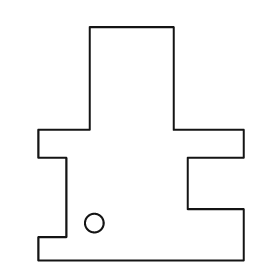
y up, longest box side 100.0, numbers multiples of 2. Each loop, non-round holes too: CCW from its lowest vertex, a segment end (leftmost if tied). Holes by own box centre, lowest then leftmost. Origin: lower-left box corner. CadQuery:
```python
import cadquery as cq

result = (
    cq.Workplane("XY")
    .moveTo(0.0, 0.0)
    .lineTo(88.0, 0.0)
    .lineTo(88.0, 22.0)
    .lineTo(64.0, 22.0)
    .lineTo(64.0, 44.0)
    .lineTo(88.0, 44.0)
    .lineTo(88.0, 56.0)
    .lineTo(58.0, 56.0)
    .lineTo(58.0, 100.0)
    .lineTo(22.0, 100.0)
    .lineTo(22.0, 56.0)
    .lineTo(0.0, 56.0)
    .lineTo(0.0, 44.0)
    .lineTo(12.0, 44.0)
    .lineTo(12.0, 10.0)
    .lineTo(0.0, 10.0)
    .close()
    .moveTo(24.0, 16.0)
    .circle(4.0)
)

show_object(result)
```